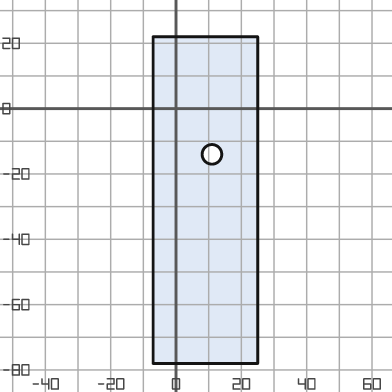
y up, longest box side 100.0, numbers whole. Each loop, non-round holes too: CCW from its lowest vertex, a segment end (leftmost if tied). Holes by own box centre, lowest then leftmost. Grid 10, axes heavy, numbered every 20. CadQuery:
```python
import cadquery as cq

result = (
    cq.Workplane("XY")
    .moveTo(-7.0, -78.0)
    .lineTo(25.0, -78.0)
    .lineTo(25.0, 22.0)
    .lineTo(-7.0, 22.0)
    .close()
    .moveTo(11.0, -14.0)
    .circle(3.0)
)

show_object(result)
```